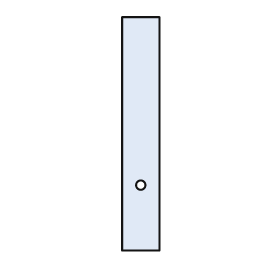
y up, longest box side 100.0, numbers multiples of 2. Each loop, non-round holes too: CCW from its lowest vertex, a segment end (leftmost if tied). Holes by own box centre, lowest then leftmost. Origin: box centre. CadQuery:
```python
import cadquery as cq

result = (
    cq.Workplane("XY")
    .moveTo(-8.0, -50.0)
    .lineTo(8.0, -50.0)
    .lineTo(8.0, 50.0)
    .lineTo(-8.0, 50.0)
    .close()
    .moveTo(0.0, -22.0)
    .circle(2.0)
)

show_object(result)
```